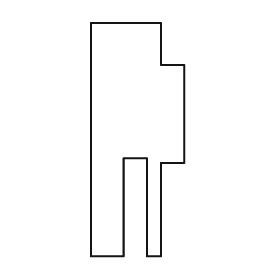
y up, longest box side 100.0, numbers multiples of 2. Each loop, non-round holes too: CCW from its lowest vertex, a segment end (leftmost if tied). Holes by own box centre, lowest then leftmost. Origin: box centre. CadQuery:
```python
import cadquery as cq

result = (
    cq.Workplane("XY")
    .moveTo(-20.0, -50.0)
    .lineTo(-6.0, -50.0)
    .lineTo(-6.0, -8.0)
    .lineTo(4.0, -8.0)
    .lineTo(4.0, -50.0)
    .lineTo(10.0, -50.0)
    .lineTo(10.0, -10.0)
    .lineTo(20.0, -10.0)
    .lineTo(20.0, 32.0)
    .lineTo(10.0, 32.0)
    .lineTo(10.0, 50.0)
    .lineTo(-20.0, 50.0)
    .close()
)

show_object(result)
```